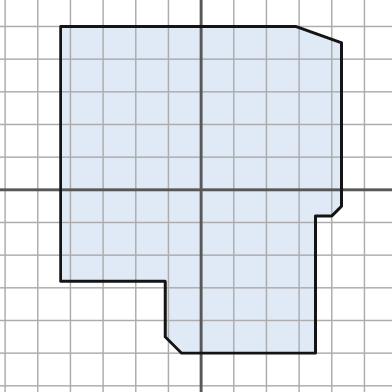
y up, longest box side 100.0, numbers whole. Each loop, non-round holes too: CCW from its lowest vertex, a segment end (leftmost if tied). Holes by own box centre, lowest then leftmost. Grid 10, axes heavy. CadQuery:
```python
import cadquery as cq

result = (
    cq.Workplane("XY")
    .moveTo(-6.0, -50.0)
    .lineTo(35.0, -50.0)
    .lineTo(35.0, -8.0)
    .lineTo(40.0, -8.0)
    .lineTo(43.0, -5.0)
    .lineTo(43.0, 45.0)
    .lineTo(29.0, 50.0)
    .lineTo(-43.0, 50.0)
    .lineTo(-43.0, -28.0)
    .lineTo(-11.0, -28.0)
    .lineTo(-11.0, -45.0)
    .close()
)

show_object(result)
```